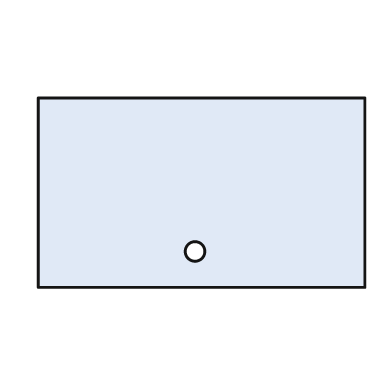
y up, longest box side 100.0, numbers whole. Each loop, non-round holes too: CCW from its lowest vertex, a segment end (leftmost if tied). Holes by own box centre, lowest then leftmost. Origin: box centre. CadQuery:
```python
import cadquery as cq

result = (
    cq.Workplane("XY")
    .moveTo(-50.0, -29.0)
    .lineTo(50.0, -29.0)
    .lineTo(50.0, 29.0)
    .lineTo(-50.0, 29.0)
    .close()
    .moveTo(-2.0, -18.0)
    .circle(3.0)
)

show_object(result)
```